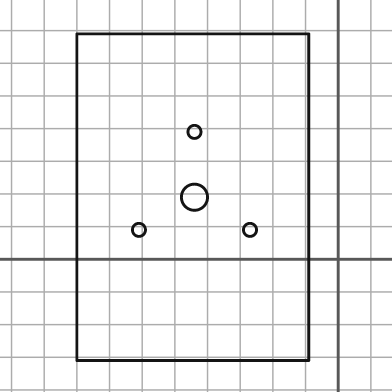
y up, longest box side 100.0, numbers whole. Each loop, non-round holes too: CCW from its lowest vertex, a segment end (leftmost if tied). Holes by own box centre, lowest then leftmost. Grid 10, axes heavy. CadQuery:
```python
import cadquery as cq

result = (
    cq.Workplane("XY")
    .moveTo(-80.0, -31.0)
    .lineTo(-9.0, -31.0)
    .lineTo(-9.0, 69.0)
    .lineTo(-80.0, 69.0)
    .close()
    .moveTo(-61.0, 9.0)
    .circle(2.0)
    .moveTo(-27.0, 9.0)
    .circle(2.0)
    .moveTo(-44.0, 19.0)
    .circle(4.0)
    .moveTo(-44.0, 39.0)
    .circle(2.0)
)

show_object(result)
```